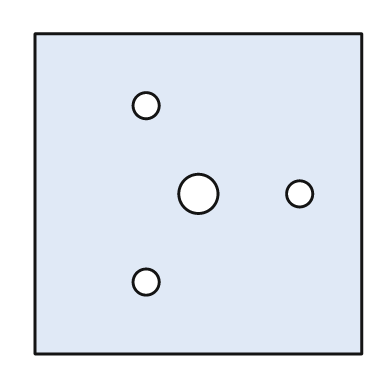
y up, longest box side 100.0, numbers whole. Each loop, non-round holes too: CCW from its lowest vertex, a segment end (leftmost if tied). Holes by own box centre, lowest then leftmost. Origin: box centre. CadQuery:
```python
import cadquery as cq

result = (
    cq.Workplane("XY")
    .moveTo(-50.0, -49.0)
    .lineTo(50.0, -49.0)
    .lineTo(50.0, 49.0)
    .lineTo(-50.0, 49.0)
    .close()
    .moveTo(-16.0, -27.0)
    .circle(4.0)
    .moveTo(0.0, 0.0)
    .circle(6.0)
    .moveTo(31.0, 0.0)
    .circle(4.0)
    .moveTo(-16.0, 27.0)
    .circle(4.0)
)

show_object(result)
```